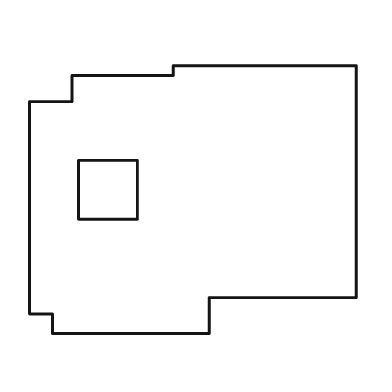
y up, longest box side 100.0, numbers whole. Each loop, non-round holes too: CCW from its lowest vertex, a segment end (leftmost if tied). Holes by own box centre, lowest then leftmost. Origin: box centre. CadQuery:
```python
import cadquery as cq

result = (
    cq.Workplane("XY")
    .moveTo(-43.0, -41.0)
    .lineTo(5.0, -41.0)
    .lineTo(5.0, -30.0)
    .lineTo(50.0, -30.0)
    .lineTo(50.0, 41.0)
    .lineTo(-6.0, 41.0)
    .lineTo(-6.0, 38.0)
    .lineTo(-37.0, 38.0)
    .lineTo(-37.0, 30.0)
    .lineTo(-50.0, 30.0)
    .lineTo(-50.0, -35.0)
    .lineTo(-43.0, -35.0)
    .close()
    .moveTo(-35.0, -6.0)
    .lineTo(-17.0, -6.0)
    .lineTo(-17.0, 12.0)
    .lineTo(-35.0, 12.0)
    .close()
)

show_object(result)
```